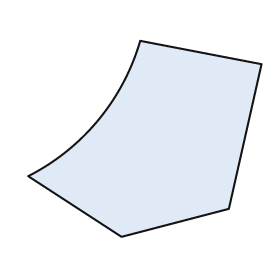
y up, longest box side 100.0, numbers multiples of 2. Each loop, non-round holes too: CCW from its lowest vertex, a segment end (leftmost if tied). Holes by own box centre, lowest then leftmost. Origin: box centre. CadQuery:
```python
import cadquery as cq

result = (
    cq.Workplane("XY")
    .moveTo(-10.0, -42.0)
    .lineTo(36.0, -30.0)
    .lineTo(50.0, 32.0)
    .lineTo(-2.0, 42.0)
    .threePointArc((-20.0, 8.0), (-50.0, -16.0))
    .close()
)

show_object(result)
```